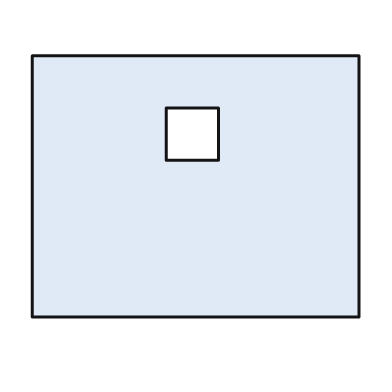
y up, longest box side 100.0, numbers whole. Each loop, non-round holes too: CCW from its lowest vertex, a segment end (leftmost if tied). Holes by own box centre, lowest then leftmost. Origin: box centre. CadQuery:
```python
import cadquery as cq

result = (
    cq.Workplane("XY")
    .moveTo(-50.0, -40.0)
    .lineTo(50.0, -40.0)
    .lineTo(50.0, 40.0)
    .lineTo(-50.0, 40.0)
    .close()
    .moveTo(-9.0, 8.0)
    .lineTo(7.0, 8.0)
    .lineTo(7.0, 24.0)
    .lineTo(-9.0, 24.0)
    .close()
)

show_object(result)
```